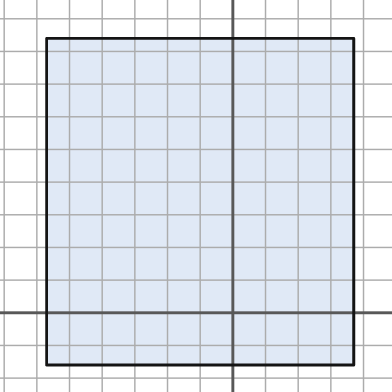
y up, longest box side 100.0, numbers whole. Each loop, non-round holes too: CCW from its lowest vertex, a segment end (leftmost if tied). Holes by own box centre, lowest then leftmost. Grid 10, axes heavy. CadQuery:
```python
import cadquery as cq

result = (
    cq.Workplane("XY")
    .moveTo(-57.0, -16.0)
    .lineTo(37.0, -16.0)
    .lineTo(37.0, 84.0)
    .lineTo(-57.0, 84.0)
    .close()
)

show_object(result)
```